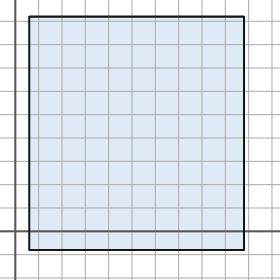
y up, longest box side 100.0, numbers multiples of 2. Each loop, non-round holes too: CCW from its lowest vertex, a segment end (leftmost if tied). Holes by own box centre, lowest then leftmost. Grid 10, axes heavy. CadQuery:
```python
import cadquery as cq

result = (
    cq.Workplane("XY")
    .moveTo(6.0, -8.0)
    .lineTo(98.0, -8.0)
    .lineTo(98.0, 92.0)
    .lineTo(6.0, 92.0)
    .close()
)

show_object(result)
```